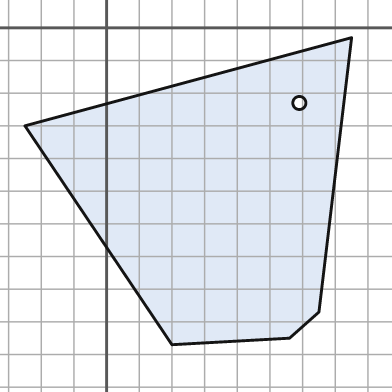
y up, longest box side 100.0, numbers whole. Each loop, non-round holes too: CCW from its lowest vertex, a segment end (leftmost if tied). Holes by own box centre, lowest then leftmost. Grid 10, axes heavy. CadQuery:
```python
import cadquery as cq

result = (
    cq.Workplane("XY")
    .moveTo(20.0, -97.0)
    .lineTo(56.0, -95.0)
    .lineTo(65.0, -87.0)
    .lineTo(75.0, -3.0)
    .lineTo(-25.0, -30.0)
    .close()
    .moveTo(59.0, -23.0)
    .circle(2.0)
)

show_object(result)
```